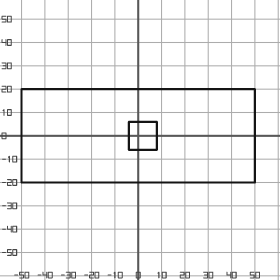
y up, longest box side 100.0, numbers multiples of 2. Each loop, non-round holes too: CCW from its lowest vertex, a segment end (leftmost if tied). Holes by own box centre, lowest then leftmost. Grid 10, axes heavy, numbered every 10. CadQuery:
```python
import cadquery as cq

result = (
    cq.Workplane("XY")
    .moveTo(-50.0, -20.0)
    .lineTo(50.0, -20.0)
    .lineTo(50.0, 20.0)
    .lineTo(-50.0, 20.0)
    .close()
    .moveTo(-4.0, -6.0)
    .lineTo(8.0, -6.0)
    .lineTo(8.0, 6.0)
    .lineTo(-4.0, 6.0)
    .close()
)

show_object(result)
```